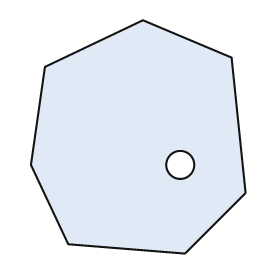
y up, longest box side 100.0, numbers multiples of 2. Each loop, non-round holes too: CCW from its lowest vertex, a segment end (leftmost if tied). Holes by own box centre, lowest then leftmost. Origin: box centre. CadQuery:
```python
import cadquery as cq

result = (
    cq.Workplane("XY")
    .moveTo(20.0, -50.0)
    .lineTo(46.0, -24.0)
    .lineTo(40.0, 34.0)
    .lineTo(2.0, 50.0)
    .lineTo(-40.0, 30.0)
    .lineTo(-46.0, -12.0)
    .lineTo(-30.0, -46.0)
    .close()
    .moveTo(18.0, -12.0)
    .circle(6.0)
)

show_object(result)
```